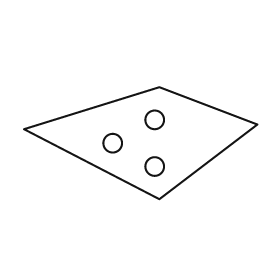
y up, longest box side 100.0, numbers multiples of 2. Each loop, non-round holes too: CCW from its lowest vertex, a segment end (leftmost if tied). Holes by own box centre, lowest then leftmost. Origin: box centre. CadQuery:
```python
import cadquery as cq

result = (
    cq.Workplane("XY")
    .moveTo(8.0, -24.0)
    .lineTo(50.0, 8.0)
    .lineTo(8.0, 24.0)
    .lineTo(-50.0, 6.0)
    .close()
    .moveTo(6.0, -10.0)
    .circle(4.0)
    .moveTo(-12.0, 0.0)
    .circle(4.0)
    .moveTo(6.0, 10.0)
    .circle(4.0)
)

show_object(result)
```